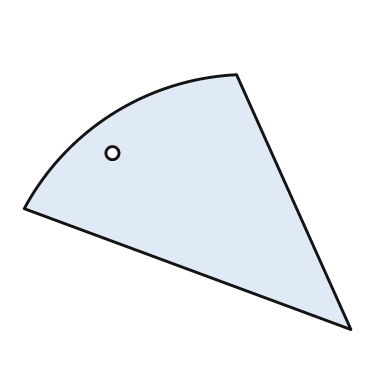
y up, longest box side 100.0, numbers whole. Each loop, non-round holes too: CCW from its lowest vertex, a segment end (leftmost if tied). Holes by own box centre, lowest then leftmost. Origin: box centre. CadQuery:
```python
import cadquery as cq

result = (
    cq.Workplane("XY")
    .moveTo(50.0, -39.0)
    .lineTo(15.0, 39.0)
    .threePointArc((-23.0, 27.0), (-50.0, -2.0))
    .close()
    .moveTo(-23.0, 15.0)
    .circle(2.0)
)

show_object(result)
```